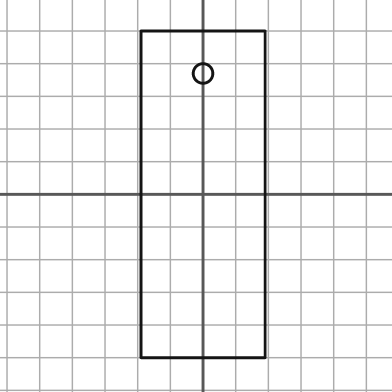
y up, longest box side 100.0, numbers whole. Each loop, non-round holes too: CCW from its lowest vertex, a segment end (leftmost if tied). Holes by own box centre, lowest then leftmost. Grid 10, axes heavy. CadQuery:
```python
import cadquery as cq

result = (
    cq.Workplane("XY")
    .moveTo(-19.0, -50.0)
    .lineTo(19.0, -50.0)
    .lineTo(19.0, 50.0)
    .lineTo(-19.0, 50.0)
    .close()
    .moveTo(0.0, 37.0)
    .circle(3.0)
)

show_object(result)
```